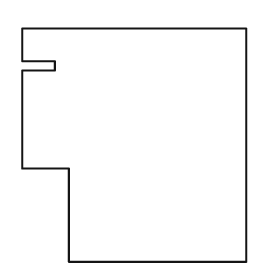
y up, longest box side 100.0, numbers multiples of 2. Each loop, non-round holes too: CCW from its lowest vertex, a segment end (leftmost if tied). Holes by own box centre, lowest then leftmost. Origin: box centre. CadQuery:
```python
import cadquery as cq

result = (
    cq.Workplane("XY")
    .moveTo(-28.0, -50.0)
    .lineTo(48.0, -50.0)
    .lineTo(48.0, 50.0)
    .lineTo(-48.0, 50.0)
    .lineTo(-48.0, 36.0)
    .lineTo(-34.0, 36.0)
    .lineTo(-34.0, 32.0)
    .lineTo(-48.0, 32.0)
    .lineTo(-48.0, -10.0)
    .lineTo(-28.0, -10.0)
    .close()
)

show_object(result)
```